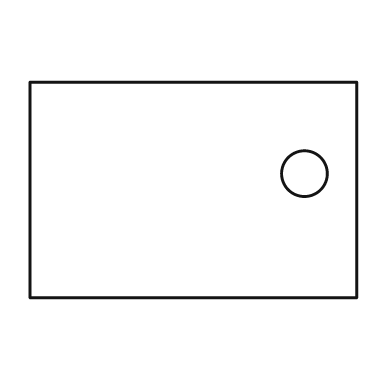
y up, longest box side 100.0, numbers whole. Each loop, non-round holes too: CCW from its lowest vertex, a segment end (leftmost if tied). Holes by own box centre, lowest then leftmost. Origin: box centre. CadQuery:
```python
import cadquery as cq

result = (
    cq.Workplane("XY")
    .moveTo(-50.0, -33.0)
    .lineTo(50.0, -33.0)
    .lineTo(50.0, 33.0)
    .lineTo(-50.0, 33.0)
    .close()
    .moveTo(34.0, 5.0)
    .circle(7.0)
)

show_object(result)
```